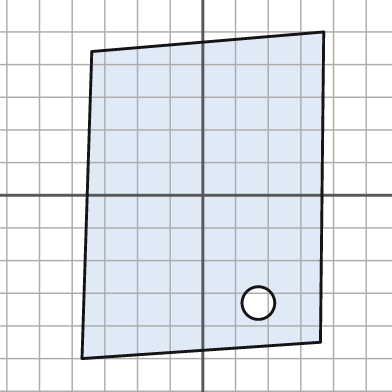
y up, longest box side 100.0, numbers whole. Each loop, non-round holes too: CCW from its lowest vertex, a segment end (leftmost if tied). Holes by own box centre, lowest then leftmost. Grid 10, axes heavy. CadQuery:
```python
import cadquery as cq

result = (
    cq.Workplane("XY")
    .moveTo(-37.0, -50.0)
    .lineTo(36.0, -45.0)
    .lineTo(37.0, 50.0)
    .lineTo(-34.0, 44.0)
    .close()
    .moveTo(17.0, -33.0)
    .circle(5.0)
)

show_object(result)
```